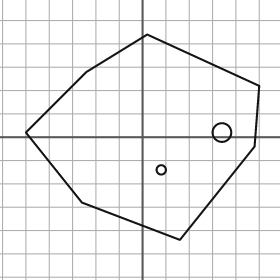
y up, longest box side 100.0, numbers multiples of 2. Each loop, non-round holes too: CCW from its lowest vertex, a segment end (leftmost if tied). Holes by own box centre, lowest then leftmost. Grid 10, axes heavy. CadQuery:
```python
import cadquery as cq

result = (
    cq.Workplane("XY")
    .moveTo(16.0, -44.0)
    .lineTo(48.0, -4.0)
    .lineTo(50.0, 22.0)
    .lineTo(2.0, 44.0)
    .lineTo(-24.0, 28.0)
    .lineTo(-50.0, 2.0)
    .lineTo(-26.0, -28.0)
    .close()
    .moveTo(8.0, -14.0)
    .circle(2.0)
    .moveTo(34.0, 2.0)
    .circle(4.0)
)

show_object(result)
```